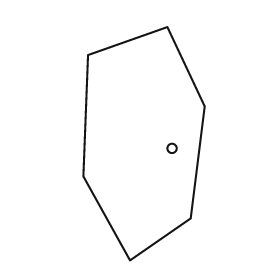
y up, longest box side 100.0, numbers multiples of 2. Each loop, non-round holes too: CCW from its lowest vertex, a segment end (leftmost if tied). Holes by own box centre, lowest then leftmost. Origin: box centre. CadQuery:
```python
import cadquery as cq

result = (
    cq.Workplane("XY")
    .moveTo(-6.0, -50.0)
    .lineTo(20.0, -32.0)
    .lineTo(26.0, 16.0)
    .lineTo(10.0, 50.0)
    .lineTo(-24.0, 38.0)
    .lineTo(-26.0, -14.0)
    .close()
    .moveTo(12.0, -2.0)
    .circle(2.0)
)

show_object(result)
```